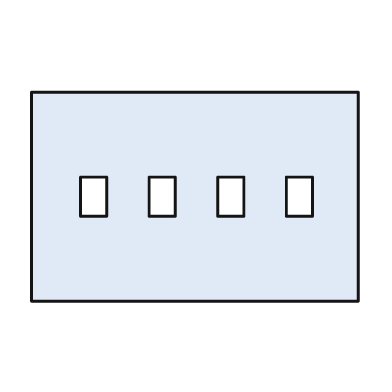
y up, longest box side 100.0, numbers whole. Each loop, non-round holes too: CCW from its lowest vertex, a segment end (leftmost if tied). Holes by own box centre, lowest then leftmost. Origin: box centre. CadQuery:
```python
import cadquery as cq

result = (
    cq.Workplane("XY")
    .moveTo(-50.0, -32.0)
    .lineTo(50.0, -32.0)
    .lineTo(50.0, 32.0)
    .lineTo(-50.0, 32.0)
    .close()
    .moveTo(-35.0, -6.0)
    .lineTo(-27.0, -6.0)
    .lineTo(-27.0, 6.0)
    .lineTo(-35.0, 6.0)
    .close()
    .moveTo(-14.0, -6.0)
    .lineTo(-6.0, -6.0)
    .lineTo(-6.0, 6.0)
    .lineTo(-14.0, 6.0)
    .close()
    .moveTo(7.0, -6.0)
    .lineTo(15.0, -6.0)
    .lineTo(15.0, 6.0)
    .lineTo(7.0, 6.0)
    .close()
    .moveTo(28.0, -6.0)
    .lineTo(36.0, -6.0)
    .lineTo(36.0, 6.0)
    .lineTo(28.0, 6.0)
    .close()
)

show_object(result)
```